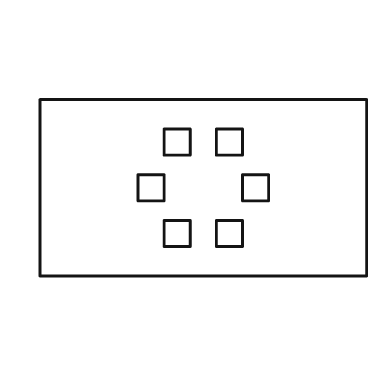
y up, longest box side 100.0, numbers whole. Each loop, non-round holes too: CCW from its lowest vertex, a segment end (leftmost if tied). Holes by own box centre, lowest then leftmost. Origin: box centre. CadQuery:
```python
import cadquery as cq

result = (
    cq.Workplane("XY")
    .moveTo(-50.0, -27.0)
    .lineTo(50.0, -27.0)
    .lineTo(50.0, 27.0)
    .lineTo(-50.0, 27.0)
    .close()
    .moveTo(-12.0, -18.0)
    .lineTo(-4.0, -18.0)
    .lineTo(-4.0, -10.0)
    .lineTo(-12.0, -10.0)
    .close()
    .moveTo(4.0, -18.0)
    .lineTo(12.0, -18.0)
    .lineTo(12.0, -10.0)
    .lineTo(4.0, -10.0)
    .close()
    .moveTo(-20.0, -4.0)
    .lineTo(-12.0, -4.0)
    .lineTo(-12.0, 4.0)
    .lineTo(-20.0, 4.0)
    .close()
    .moveTo(12.0, -4.0)
    .lineTo(20.0, -4.0)
    .lineTo(20.0, 4.0)
    .lineTo(12.0, 4.0)
    .close()
    .moveTo(-12.0, 10.0)
    .lineTo(-4.0, 10.0)
    .lineTo(-4.0, 18.0)
    .lineTo(-12.0, 18.0)
    .close()
    .moveTo(4.0, 10.0)
    .lineTo(12.0, 10.0)
    .lineTo(12.0, 18.0)
    .lineTo(4.0, 18.0)
    .close()
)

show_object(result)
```